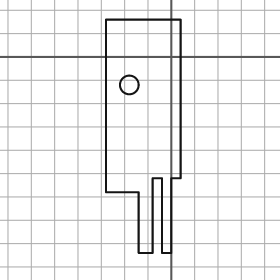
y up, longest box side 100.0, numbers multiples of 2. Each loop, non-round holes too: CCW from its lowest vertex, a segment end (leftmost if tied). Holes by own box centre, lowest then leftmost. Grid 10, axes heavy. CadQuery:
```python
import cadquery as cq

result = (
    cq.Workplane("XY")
    .moveTo(-14.0, -84.0)
    .lineTo(-8.0, -84.0)
    .lineTo(-8.0, -52.0)
    .lineTo(-4.0, -52.0)
    .lineTo(-4.0, -84.0)
    .lineTo(0.0, -84.0)
    .lineTo(0.0, -52.0)
    .lineTo(4.0, -52.0)
    .lineTo(4.0, 16.0)
    .lineTo(-28.0, 16.0)
    .lineTo(-28.0, -58.0)
    .lineTo(-14.0, -58.0)
    .close()
    .moveTo(-18.0, -12.0)
    .circle(4.0)
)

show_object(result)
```